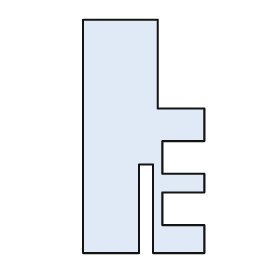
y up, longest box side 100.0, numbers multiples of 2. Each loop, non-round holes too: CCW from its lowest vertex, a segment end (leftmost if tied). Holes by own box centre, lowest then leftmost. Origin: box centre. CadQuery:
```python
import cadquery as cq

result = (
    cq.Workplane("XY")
    .moveTo(-26.0, -50.0)
    .lineTo(-2.0, -50.0)
    .lineTo(-2.0, -12.0)
    .lineTo(4.0, -12.0)
    .lineTo(4.0, -50.0)
    .lineTo(26.0, -50.0)
    .lineTo(26.0, -38.0)
    .lineTo(8.0, -38.0)
    .lineTo(8.0, -24.0)
    .lineTo(26.0, -24.0)
    .lineTo(26.0, -16.0)
    .lineTo(8.0, -16.0)
    .lineTo(8.0, -2.0)
    .lineTo(26.0, -2.0)
    .lineTo(26.0, 12.0)
    .lineTo(6.0, 12.0)
    .lineTo(6.0, 50.0)
    .lineTo(-26.0, 50.0)
    .close()
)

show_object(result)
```